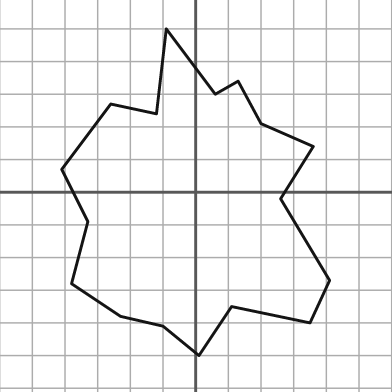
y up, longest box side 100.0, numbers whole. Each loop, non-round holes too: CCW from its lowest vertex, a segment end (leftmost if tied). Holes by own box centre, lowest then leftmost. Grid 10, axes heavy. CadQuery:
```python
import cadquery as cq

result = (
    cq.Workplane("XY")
    .moveTo(1.0, -50.0)
    .lineTo(11.0, -35.0)
    .lineTo(35.0, -40.0)
    .lineTo(41.0, -27.0)
    .lineTo(26.0, -2.0)
    .lineTo(36.0, 14.0)
    .lineTo(20.0, 21.0)
    .lineTo(13.0, 34.0)
    .lineTo(6.0, 30.0)
    .lineTo(-9.0, 50.0)
    .lineTo(-12.0, 24.0)
    .lineTo(-26.0, 27.0)
    .lineTo(-41.0, 7.0)
    .lineTo(-33.0, -9.0)
    .lineTo(-38.0, -28.0)
    .lineTo(-23.0, -38.0)
    .lineTo(-10.0, -41.0)
    .close()
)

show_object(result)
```